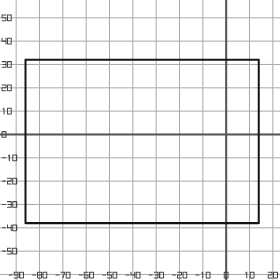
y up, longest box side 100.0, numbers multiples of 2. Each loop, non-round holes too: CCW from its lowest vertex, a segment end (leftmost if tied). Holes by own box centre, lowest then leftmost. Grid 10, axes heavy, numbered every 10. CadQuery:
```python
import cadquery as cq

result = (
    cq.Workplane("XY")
    .moveTo(-86.0, -38.0)
    .lineTo(14.0, -38.0)
    .lineTo(14.0, 32.0)
    .lineTo(-86.0, 32.0)
    .close()
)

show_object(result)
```